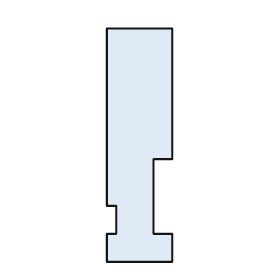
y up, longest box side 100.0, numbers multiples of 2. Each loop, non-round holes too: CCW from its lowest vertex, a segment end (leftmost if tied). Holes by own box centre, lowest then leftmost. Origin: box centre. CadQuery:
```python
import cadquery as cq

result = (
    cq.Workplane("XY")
    .moveTo(-14.0, -50.0)
    .lineTo(14.0, -50.0)
    .lineTo(14.0, -38.0)
    .lineTo(6.0, -38.0)
    .lineTo(6.0, -6.0)
    .lineTo(14.0, -6.0)
    .lineTo(14.0, 50.0)
    .lineTo(-14.0, 50.0)
    .lineTo(-14.0, -26.0)
    .lineTo(-10.0, -26.0)
    .lineTo(-10.0, -38.0)
    .lineTo(-14.0, -38.0)
    .close()
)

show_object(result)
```